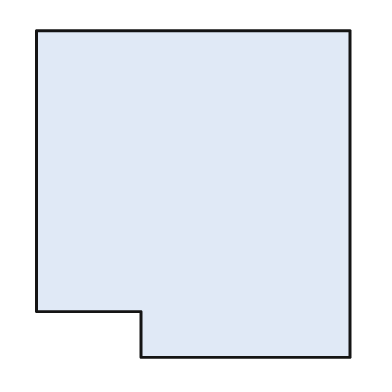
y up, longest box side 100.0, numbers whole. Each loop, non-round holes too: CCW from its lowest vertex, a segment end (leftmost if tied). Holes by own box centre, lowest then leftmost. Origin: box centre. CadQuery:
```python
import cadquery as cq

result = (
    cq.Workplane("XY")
    .moveTo(-16.0, -50.0)
    .lineTo(48.0, -50.0)
    .lineTo(48.0, 50.0)
    .lineTo(-48.0, 50.0)
    .lineTo(-48.0, -36.0)
    .lineTo(-16.0, -36.0)
    .close()
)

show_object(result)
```